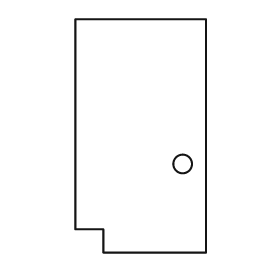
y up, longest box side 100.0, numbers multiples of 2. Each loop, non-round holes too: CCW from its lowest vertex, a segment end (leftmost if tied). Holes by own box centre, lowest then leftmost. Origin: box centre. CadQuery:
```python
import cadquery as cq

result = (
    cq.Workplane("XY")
    .moveTo(-16.0, -50.0)
    .lineTo(28.0, -50.0)
    .lineTo(28.0, 50.0)
    .lineTo(-28.0, 50.0)
    .lineTo(-28.0, -40.0)
    .lineTo(-16.0, -40.0)
    .close()
    .moveTo(18.0, -12.0)
    .circle(4.0)
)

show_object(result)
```